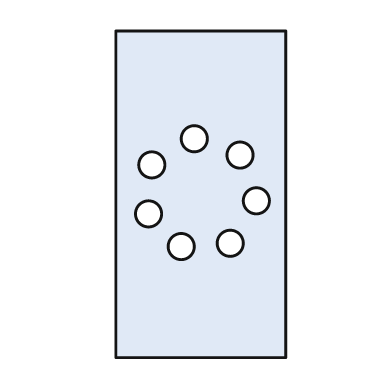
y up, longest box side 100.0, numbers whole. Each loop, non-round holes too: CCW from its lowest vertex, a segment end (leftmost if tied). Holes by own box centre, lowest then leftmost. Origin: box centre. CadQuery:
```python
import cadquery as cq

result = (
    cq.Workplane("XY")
    .moveTo(-26.0, -50.0)
    .lineTo(26.0, -50.0)
    .lineTo(26.0, 50.0)
    .lineTo(-26.0, 50.0)
    .close()
    .moveTo(-6.0, -16.0)
    .circle(4.0)
    .moveTo(9.0, -15.0)
    .circle(4.0)
    .moveTo(-16.0, -6.0)
    .circle(4.0)
    .moveTo(17.0, -2.0)
    .circle(4.0)
    .moveTo(-15.0, 9.0)
    .circle(4.0)
    .moveTo(12.0, 12.0)
    .circle(4.0)
    .moveTo(-2.0, 17.0)
    .circle(4.0)
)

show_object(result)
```